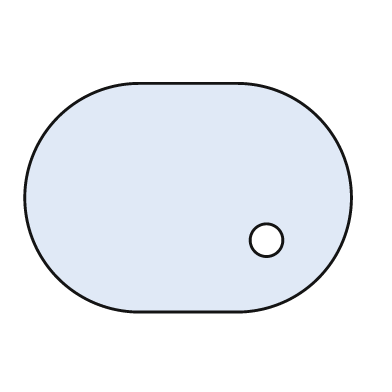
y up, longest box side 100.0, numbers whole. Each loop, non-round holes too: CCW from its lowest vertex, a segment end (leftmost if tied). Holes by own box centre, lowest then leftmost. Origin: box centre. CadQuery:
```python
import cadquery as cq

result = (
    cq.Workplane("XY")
    .moveTo(-15.0, -35.0)
    .lineTo(15.0, -35.0)
    .threePointArc((50.0, 0.0), (15.0, 35.0))
    .lineTo(-15.0, 35.0)
    .threePointArc((-50.0, 0.0), (-15.0, -35.0))
    .close()
    .moveTo(24.0, -13.0)
    .circle(5.0)
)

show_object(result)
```